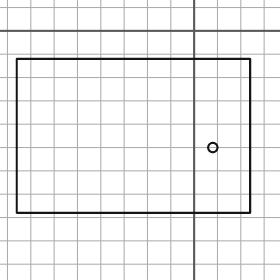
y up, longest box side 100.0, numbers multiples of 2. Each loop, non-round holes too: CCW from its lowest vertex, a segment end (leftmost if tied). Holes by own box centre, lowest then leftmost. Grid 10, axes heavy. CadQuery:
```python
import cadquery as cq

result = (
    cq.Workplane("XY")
    .moveTo(-76.0, -78.0)
    .lineTo(24.0, -78.0)
    .lineTo(24.0, -12.0)
    .lineTo(-76.0, -12.0)
    .close()
    .moveTo(8.0, -50.0)
    .circle(2.0)
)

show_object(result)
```